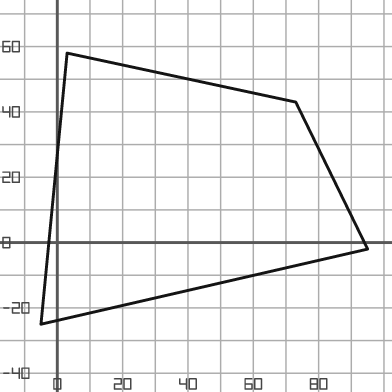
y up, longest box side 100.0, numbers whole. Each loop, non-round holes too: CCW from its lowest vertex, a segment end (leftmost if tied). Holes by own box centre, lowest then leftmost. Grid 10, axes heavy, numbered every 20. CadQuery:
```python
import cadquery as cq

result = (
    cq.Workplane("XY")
    .moveTo(-5.0, -25.0)
    .lineTo(95.0, -2.0)
    .lineTo(73.0, 43.0)
    .lineTo(3.0, 58.0)
    .close()
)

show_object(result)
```